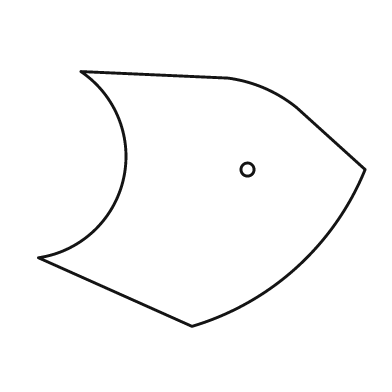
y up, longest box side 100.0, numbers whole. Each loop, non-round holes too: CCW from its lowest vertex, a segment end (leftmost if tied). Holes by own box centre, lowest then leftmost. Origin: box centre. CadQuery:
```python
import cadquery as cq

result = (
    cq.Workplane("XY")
    .moveTo(-3.0, -39.0)
    .threePointArc((29.0, -21.0), (50.0, 9.0))
    .lineTo(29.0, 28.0)
    .threePointArc((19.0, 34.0), (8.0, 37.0))
    .lineTo(-37.0, 39.0)
    .threePointArc((-24.0, 6.0), (-50.0, -18.0))
    .close()
    .moveTo(14.0, 9.0)
    .circle(2.0)
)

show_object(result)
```